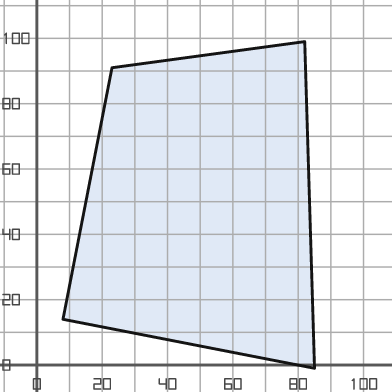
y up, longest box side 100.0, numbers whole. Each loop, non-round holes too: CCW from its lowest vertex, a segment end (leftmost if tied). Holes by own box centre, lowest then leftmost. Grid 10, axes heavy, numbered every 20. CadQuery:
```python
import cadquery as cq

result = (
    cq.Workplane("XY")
    .moveTo(85.0, -1.0)
    .lineTo(82.0, 99.0)
    .lineTo(23.0, 91.0)
    .lineTo(8.0, 14.0)
    .close()
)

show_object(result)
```